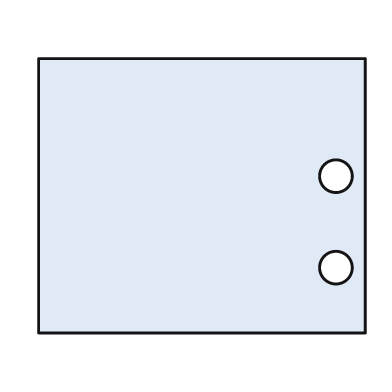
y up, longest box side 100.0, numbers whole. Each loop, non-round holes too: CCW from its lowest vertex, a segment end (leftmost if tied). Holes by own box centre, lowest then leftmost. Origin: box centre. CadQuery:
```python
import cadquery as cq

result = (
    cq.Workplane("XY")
    .moveTo(-50.0, -42.0)
    .lineTo(50.0, -42.0)
    .lineTo(50.0, 42.0)
    .lineTo(-50.0, 42.0)
    .close()
    .moveTo(41.0, -22.0)
    .circle(5.0)
    .moveTo(41.0, 6.0)
    .circle(5.0)
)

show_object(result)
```